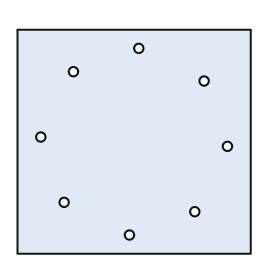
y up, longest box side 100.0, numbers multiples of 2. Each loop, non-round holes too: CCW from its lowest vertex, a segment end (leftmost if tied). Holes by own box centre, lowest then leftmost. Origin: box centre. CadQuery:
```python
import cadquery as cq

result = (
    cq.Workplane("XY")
    .moveTo(-50.0, -48.0)
    .lineTo(50.0, -48.0)
    .lineTo(50.0, 48.0)
    .lineTo(-50.0, 48.0)
    .close()
    .moveTo(-2.0, -40.0)
    .circle(2.0)
    .moveTo(26.0, -30.0)
    .circle(2.0)
    .moveTo(-30.0, -26.0)
    .circle(2.0)
    .moveTo(40.0, -2.0)
    .circle(2.0)
    .moveTo(-40.0, 2.0)
    .circle(2.0)
    .moveTo(30.0, 26.0)
    .circle(2.0)
    .moveTo(-26.0, 30.0)
    .circle(2.0)
    .moveTo(2.0, 40.0)
    .circle(2.0)
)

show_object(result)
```